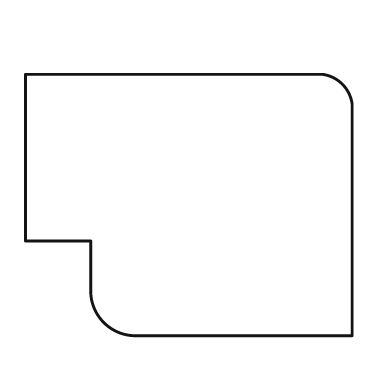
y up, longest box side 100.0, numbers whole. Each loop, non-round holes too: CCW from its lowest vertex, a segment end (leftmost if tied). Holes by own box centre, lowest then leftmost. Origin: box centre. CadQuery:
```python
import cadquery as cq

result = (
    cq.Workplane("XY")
    .moveTo(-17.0, -40.0)
    .lineTo(50.0, -40.0)
    .lineTo(50.0, 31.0)
    .threePointArc((47.0, 37.0), (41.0, 40.0))
    .lineTo(-50.0, 40.0)
    .lineTo(-50.0, -11.0)
    .lineTo(-30.0, -11.0)
    .lineTo(-30.0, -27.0)
    .threePointArc((-26.0, -36.0), (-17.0, -40.0))
    .close()
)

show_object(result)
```